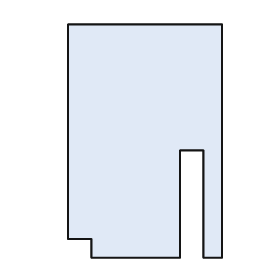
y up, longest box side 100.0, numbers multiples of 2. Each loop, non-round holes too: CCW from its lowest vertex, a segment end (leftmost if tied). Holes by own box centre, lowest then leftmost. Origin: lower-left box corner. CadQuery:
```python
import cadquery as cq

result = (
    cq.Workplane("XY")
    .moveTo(10.0, 0.0)
    .lineTo(48.0, 0.0)
    .lineTo(48.0, 46.0)
    .lineTo(58.0, 46.0)
    .lineTo(58.0, 0.0)
    .lineTo(66.0, 0.0)
    .lineTo(66.0, 100.0)
    .lineTo(0.0, 100.0)
    .lineTo(0.0, 8.0)
    .lineTo(10.0, 8.0)
    .close()
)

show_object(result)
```